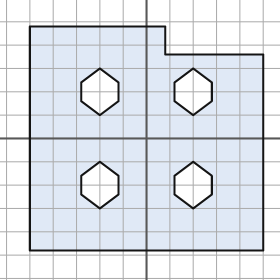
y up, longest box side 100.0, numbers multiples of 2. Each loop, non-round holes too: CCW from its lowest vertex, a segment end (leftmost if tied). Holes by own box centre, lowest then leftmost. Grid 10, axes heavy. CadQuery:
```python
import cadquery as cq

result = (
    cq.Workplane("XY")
    .moveTo(-50.0, -48.0)
    .lineTo(50.0, -48.0)
    .lineTo(50.0, 36.0)
    .lineTo(8.0, 36.0)
    .lineTo(8.0, 48.0)
    .lineTo(-50.0, 48.0)
    .close()
    .moveTo(-20.0, -30.0)
    .lineTo(-12.0, -24.0)
    .lineTo(-12.0, -16.0)
    .lineTo(-20.0, -10.0)
    .lineTo(-28.0, -16.0)
    .lineTo(-28.0, -24.0)
    .close()
    .moveTo(20.0, -30.0)
    .lineTo(28.0, -24.0)
    .lineTo(28.0, -16.0)
    .lineTo(20.0, -10.0)
    .lineTo(12.0, -16.0)
    .lineTo(12.0, -24.0)
    .close()
    .moveTo(-20.0, 10.0)
    .lineTo(-12.0, 16.0)
    .lineTo(-12.0, 24.0)
    .lineTo(-20.0, 30.0)
    .lineTo(-28.0, 24.0)
    .lineTo(-28.0, 16.0)
    .close()
    .moveTo(20.0, 10.0)
    .lineTo(28.0, 16.0)
    .lineTo(28.0, 24.0)
    .lineTo(20.0, 30.0)
    .lineTo(12.0, 24.0)
    .lineTo(12.0, 16.0)
    .close()
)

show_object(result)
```